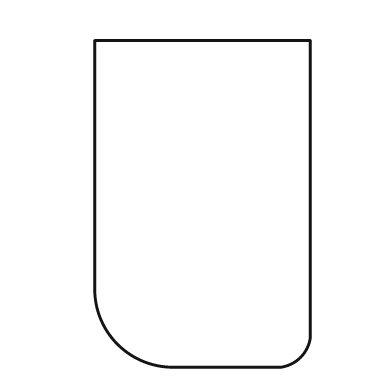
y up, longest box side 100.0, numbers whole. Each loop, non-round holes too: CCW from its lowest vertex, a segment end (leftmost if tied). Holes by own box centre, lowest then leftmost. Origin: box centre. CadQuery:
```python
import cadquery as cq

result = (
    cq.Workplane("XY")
    .moveTo(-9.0, -50.0)
    .lineTo(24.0, -50.0)
    .threePointArc((30.0, -47.0), (33.0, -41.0))
    .lineTo(33.0, 50.0)
    .lineTo(-33.0, 50.0)
    .lineTo(-33.0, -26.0)
    .threePointArc((-26.0, -43.0), (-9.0, -50.0))
    .close()
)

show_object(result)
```